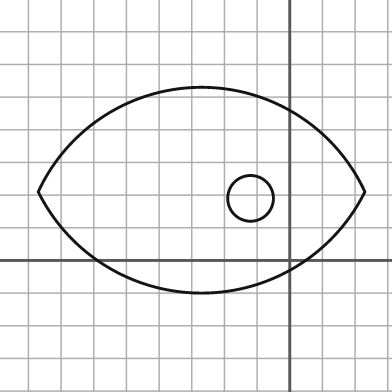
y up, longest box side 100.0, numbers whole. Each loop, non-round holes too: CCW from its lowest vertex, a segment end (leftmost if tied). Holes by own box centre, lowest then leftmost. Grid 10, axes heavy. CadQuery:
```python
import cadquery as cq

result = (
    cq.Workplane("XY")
    .moveTo(-77.0, 21.0)
    .threePointArc((-27.0, -10.0), (23.0, 21.0))
    .threePointArc((-27.0, 53.0), (-77.0, 21.0))
    .close()
    .moveTo(-12.0, 19.0)
    .circle(7.0)
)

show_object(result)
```